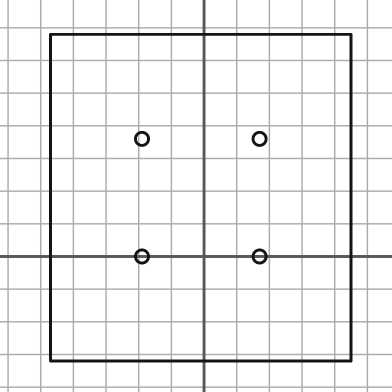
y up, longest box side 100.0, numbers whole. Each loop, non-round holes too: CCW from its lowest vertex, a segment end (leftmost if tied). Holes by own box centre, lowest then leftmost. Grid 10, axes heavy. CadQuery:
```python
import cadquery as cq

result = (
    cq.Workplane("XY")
    .moveTo(-47.0, -32.0)
    .lineTo(45.0, -32.0)
    .lineTo(45.0, 68.0)
    .lineTo(-47.0, 68.0)
    .close()
    .moveTo(-19.0, 0.0)
    .circle(2.0)
    .moveTo(17.0, 0.0)
    .circle(2.0)
    .moveTo(-19.0, 36.0)
    .circle(2.0)
    .moveTo(17.0, 36.0)
    .circle(2.0)
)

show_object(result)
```